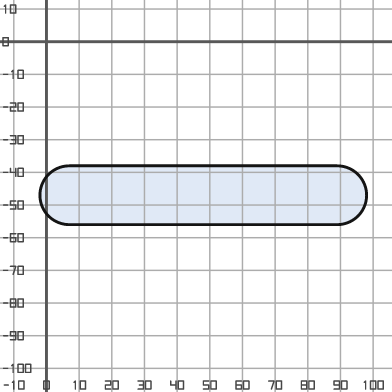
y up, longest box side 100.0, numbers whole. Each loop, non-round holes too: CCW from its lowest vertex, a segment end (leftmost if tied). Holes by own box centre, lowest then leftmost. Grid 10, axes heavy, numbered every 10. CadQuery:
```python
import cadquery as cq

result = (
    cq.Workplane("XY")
    .moveTo(7.0, -56.0)
    .lineTo(89.0, -56.0)
    .threePointArc((98.0, -47.0), (89.0, -38.0))
    .lineTo(7.0, -38.0)
    .threePointArc((-2.0, -47.0), (7.0, -56.0))
    .close()
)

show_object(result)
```